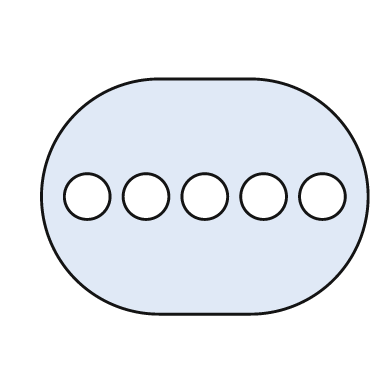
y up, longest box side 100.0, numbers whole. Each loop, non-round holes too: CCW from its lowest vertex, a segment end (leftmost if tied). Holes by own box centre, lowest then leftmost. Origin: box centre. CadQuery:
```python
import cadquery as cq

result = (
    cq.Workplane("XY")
    .moveTo(-14.0, -36.0)
    .lineTo(14.0, -36.0)
    .threePointArc((50.0, 0.0), (14.0, 36.0))
    .lineTo(-14.0, 36.0)
    .threePointArc((-50.0, 0.0), (-14.0, -36.0))
    .close()
    .moveTo(-36.0, 0.0)
    .circle(7.0)
    .moveTo(-18.0, 0.0)
    .circle(7.0)
    .moveTo(0.0, 0.0)
    .circle(7.0)
    .moveTo(18.0, 0.0)
    .circle(7.0)
    .moveTo(36.0, 0.0)
    .circle(7.0)
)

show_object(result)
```